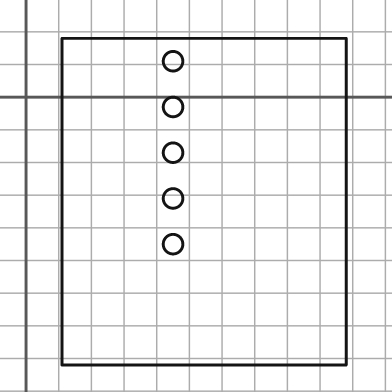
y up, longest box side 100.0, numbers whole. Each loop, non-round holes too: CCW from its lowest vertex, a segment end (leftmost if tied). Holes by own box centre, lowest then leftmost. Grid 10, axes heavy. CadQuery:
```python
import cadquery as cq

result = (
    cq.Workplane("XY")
    .moveTo(11.0, -82.0)
    .lineTo(98.0, -82.0)
    .lineTo(98.0, 18.0)
    .lineTo(11.0, 18.0)
    .close()
    .moveTo(45.0, -45.0)
    .circle(3.0)
    .moveTo(45.0, -31.0)
    .circle(3.0)
    .moveTo(45.0, -17.0)
    .circle(3.0)
    .moveTo(45.0, -3.0)
    .circle(3.0)
    .moveTo(45.0, 11.0)
    .circle(3.0)
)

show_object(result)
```